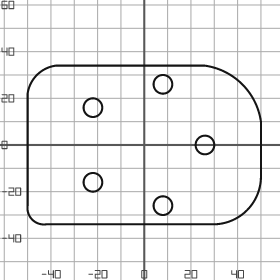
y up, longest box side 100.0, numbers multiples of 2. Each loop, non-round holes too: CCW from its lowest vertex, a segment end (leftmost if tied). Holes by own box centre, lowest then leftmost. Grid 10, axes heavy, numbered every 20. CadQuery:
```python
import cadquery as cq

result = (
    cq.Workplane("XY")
    .moveTo(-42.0, -34.0)
    .lineTo(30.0, -34.0)
    .threePointArc((44.0, -28.0), (50.0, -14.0))
    .lineTo(50.0, 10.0)
    .threePointArc((42.0, 26.0), (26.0, 34.0))
    .lineTo(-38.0, 34.0)
    .threePointArc((-46.0, 30.0), (-50.0, 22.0))
    .lineTo(-50.0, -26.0)
    .threePointArc((-48.0, -32.0), (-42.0, -34.0))
    .close()
    .moveTo(8.0, -26.0)
    .circle(4.0)
    .moveTo(-22.0, -16.0)
    .circle(4.0)
    .moveTo(26.0, 0.0)
    .circle(4.0)
    .moveTo(-22.0, 16.0)
    .circle(4.0)
    .moveTo(8.0, 26.0)
    .circle(4.0)
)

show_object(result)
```